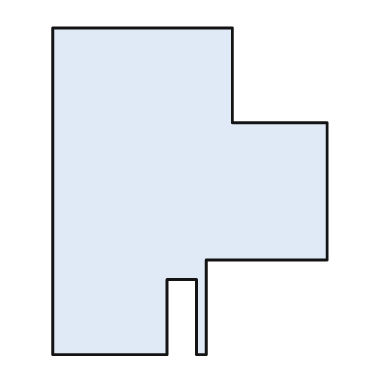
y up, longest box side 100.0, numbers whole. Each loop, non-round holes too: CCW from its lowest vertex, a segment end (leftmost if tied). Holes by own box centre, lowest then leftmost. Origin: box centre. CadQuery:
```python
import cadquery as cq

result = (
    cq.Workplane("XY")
    .moveTo(-42.0, -50.0)
    .lineTo(-7.0, -50.0)
    .lineTo(-7.0, -27.0)
    .lineTo(2.0, -27.0)
    .lineTo(2.0, -50.0)
    .lineTo(5.0, -50.0)
    .lineTo(5.0, -21.0)
    .lineTo(42.0, -21.0)
    .lineTo(42.0, 21.0)
    .lineTo(13.0, 21.0)
    .lineTo(13.0, 50.0)
    .lineTo(-42.0, 50.0)
    .close()
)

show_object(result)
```